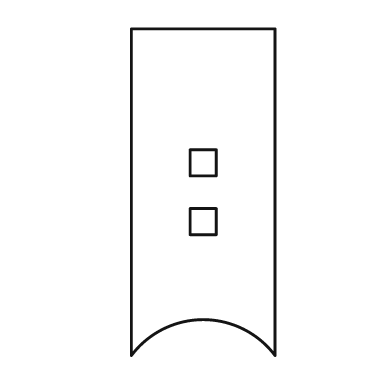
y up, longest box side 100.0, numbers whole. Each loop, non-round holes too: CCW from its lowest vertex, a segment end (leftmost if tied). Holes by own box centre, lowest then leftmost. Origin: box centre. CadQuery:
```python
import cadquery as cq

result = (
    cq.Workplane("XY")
    .moveTo(-22.0, -50.0)
    .threePointArc((0.0, -39.0), (22.0, -50.0))
    .lineTo(22.0, 50.0)
    .lineTo(-22.0, 50.0)
    .close()
    .moveTo(-4.0, -13.0)
    .lineTo(4.0, -13.0)
    .lineTo(4.0, -5.0)
    .lineTo(-4.0, -5.0)
    .close()
    .moveTo(-4.0, 5.0)
    .lineTo(4.0, 5.0)
    .lineTo(4.0, 13.0)
    .lineTo(-4.0, 13.0)
    .close()
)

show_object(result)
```